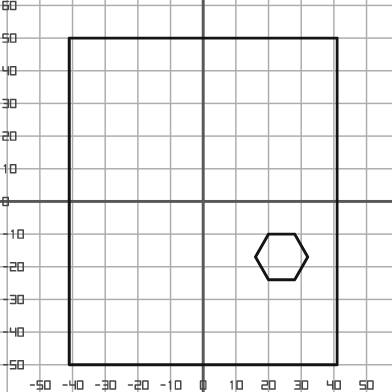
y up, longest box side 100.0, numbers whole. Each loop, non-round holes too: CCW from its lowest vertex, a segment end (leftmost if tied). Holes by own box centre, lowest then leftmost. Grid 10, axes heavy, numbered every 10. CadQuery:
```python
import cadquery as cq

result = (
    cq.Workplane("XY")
    .moveTo(-41.0, -50.0)
    .lineTo(41.0, -50.0)
    .lineTo(41.0, 50.0)
    .lineTo(-41.0, 50.0)
    .close()
    .moveTo(20.0, -24.0)
    .lineTo(28.0, -24.0)
    .lineTo(32.0, -17.0)
    .lineTo(28.0, -10.0)
    .lineTo(20.0, -10.0)
    .lineTo(16.0, -17.0)
    .close()
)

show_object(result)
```